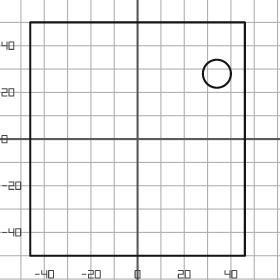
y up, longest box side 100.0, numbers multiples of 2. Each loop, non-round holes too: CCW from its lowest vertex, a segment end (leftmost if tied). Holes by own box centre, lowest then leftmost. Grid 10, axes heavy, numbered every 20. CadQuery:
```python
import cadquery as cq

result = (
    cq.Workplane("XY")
    .moveTo(-46.0, -50.0)
    .lineTo(46.0, -50.0)
    .lineTo(46.0, 50.0)
    .lineTo(-46.0, 50.0)
    .close()
    .moveTo(34.0, 28.0)
    .circle(6.0)
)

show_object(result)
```